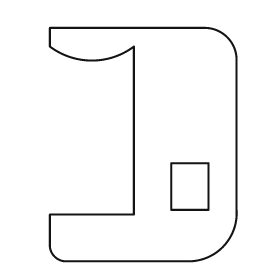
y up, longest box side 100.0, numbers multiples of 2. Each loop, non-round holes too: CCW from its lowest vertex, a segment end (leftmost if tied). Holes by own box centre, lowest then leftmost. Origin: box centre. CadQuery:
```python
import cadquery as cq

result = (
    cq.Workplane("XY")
    .moveTo(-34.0, -50.0)
    .lineTo(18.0, -50.0)
    .threePointArc((34.0, -44.0), (40.0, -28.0))
    .lineTo(40.0, 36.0)
    .threePointArc((36.0, 46.0), (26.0, 50.0))
    .lineTo(-40.0, 50.0)
    .lineTo(-40.0, 42.0)
    .threePointArc((-22.0, 36.0), (-4.0, 42.0))
    .lineTo(-4.0, -30.0)
    .lineTo(-40.0, -30.0)
    .lineTo(-40.0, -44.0)
    .threePointArc((-38.0, -48.0), (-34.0, -50.0))
    .close()
    .moveTo(12.0, -28.0)
    .lineTo(28.0, -28.0)
    .lineTo(28.0, -8.0)
    .lineTo(12.0, -8.0)
    .close()
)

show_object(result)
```